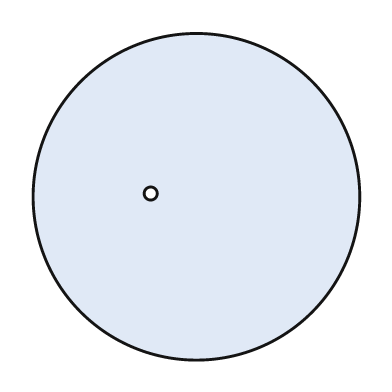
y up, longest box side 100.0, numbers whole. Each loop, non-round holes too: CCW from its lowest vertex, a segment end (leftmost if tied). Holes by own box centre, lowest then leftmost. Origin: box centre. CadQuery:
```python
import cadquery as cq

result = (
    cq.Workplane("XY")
    .moveTo(0.0, 0.0)
    .circle(50.0)
    .moveTo(-14.0, 1.0)
    .circle(2.0)
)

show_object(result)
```